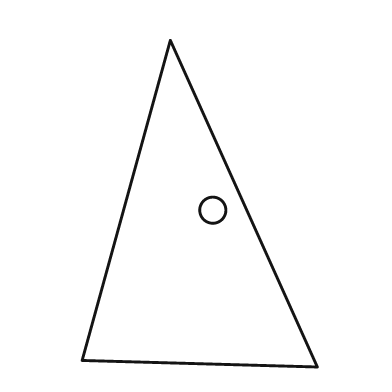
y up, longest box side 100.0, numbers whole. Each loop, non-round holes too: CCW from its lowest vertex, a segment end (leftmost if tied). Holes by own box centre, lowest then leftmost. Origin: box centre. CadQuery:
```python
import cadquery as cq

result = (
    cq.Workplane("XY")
    .moveTo(36.0, -50.0)
    .lineTo(-9.0, 50.0)
    .lineTo(-36.0, -48.0)
    .close()
    .moveTo(4.0, -2.0)
    .circle(4.0)
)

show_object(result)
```